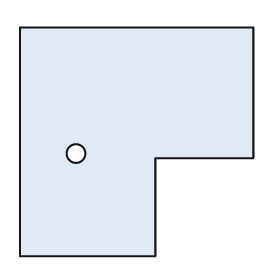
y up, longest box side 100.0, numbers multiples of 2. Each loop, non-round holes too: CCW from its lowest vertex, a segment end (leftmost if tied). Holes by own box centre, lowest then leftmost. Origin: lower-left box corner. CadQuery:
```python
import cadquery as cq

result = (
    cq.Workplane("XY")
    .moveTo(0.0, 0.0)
    .lineTo(58.0, 0.0)
    .lineTo(58.0, 42.0)
    .lineTo(100.0, 42.0)
    .lineTo(100.0, 98.0)
    .lineTo(0.0, 98.0)
    .close()
    .moveTo(24.0, 44.0)
    .circle(4.0)
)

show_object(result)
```